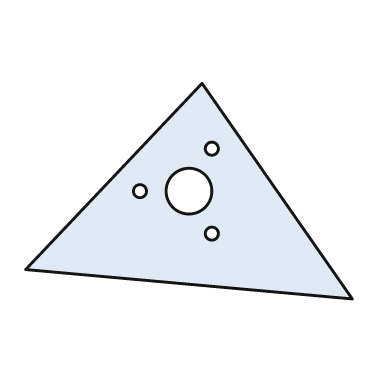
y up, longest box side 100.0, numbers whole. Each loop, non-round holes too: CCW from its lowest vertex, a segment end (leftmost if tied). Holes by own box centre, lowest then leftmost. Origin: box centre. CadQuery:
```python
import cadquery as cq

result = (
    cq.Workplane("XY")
    .moveTo(50.0, -33.0)
    .lineTo(4.0, 33.0)
    .lineTo(-50.0, -24.0)
    .close()
    .moveTo(7.0, -13.0)
    .circle(2.0)
    .moveTo(-15.0, 0.0)
    .circle(2.0)
    .moveTo(0.0, 0.0)
    .circle(7.0)
    .moveTo(7.0, 13.0)
    .circle(2.0)
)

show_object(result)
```